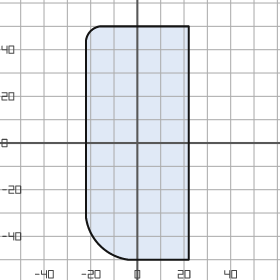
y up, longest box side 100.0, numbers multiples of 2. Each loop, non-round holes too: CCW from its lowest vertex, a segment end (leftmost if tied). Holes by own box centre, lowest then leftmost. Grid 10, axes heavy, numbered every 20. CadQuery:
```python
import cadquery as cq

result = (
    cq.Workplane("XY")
    .moveTo(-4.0, -50.0)
    .lineTo(22.0, -50.0)
    .lineTo(22.0, 50.0)
    .lineTo(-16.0, 50.0)
    .threePointArc((-20.0, 48.0), (-22.0, 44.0))
    .lineTo(-22.0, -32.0)
    .threePointArc((-16.0, -44.0), (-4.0, -50.0))
    .close()
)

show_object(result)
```